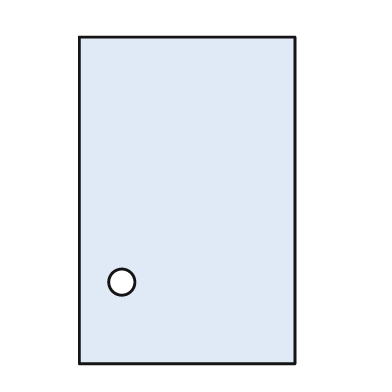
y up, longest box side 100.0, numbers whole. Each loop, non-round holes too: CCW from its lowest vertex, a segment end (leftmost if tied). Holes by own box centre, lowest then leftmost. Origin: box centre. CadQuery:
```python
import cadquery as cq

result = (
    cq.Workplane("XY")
    .moveTo(-33.0, -50.0)
    .lineTo(33.0, -50.0)
    .lineTo(33.0, 50.0)
    .lineTo(-33.0, 50.0)
    .close()
    .moveTo(-20.0, -25.0)
    .circle(4.0)
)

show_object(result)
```